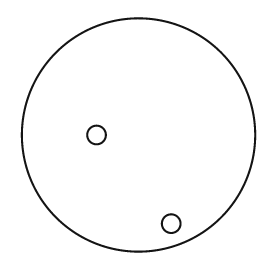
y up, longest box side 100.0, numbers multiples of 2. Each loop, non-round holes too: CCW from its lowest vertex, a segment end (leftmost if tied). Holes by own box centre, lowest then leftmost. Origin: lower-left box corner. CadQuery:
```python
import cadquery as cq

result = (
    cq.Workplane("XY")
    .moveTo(50.0, 50.0)
    .circle(50.0)
    .moveTo(64.0, 12.0)
    .circle(4.0)
    .moveTo(32.0, 50.0)
    .circle(4.0)
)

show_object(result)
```